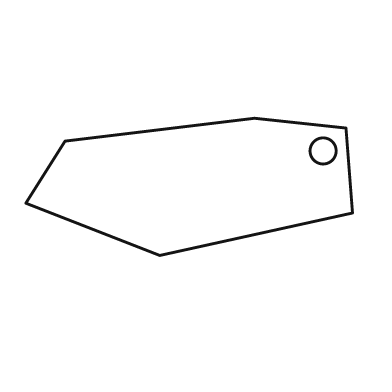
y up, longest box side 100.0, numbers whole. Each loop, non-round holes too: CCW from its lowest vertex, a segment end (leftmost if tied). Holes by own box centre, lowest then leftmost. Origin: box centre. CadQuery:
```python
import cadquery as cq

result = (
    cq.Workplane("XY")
    .moveTo(-9.0, -21.0)
    .lineTo(50.0, -8.0)
    .lineTo(48.0, 18.0)
    .lineTo(20.0, 21.0)
    .lineTo(-38.0, 14.0)
    .lineTo(-50.0, -5.0)
    .close()
    .moveTo(41.0, 11.0)
    .circle(4.0)
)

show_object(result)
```